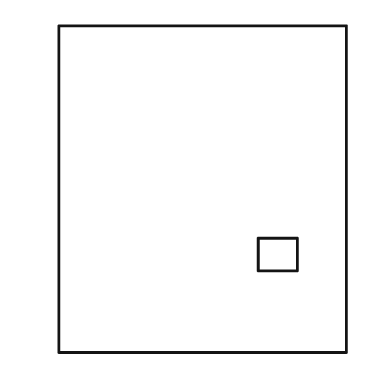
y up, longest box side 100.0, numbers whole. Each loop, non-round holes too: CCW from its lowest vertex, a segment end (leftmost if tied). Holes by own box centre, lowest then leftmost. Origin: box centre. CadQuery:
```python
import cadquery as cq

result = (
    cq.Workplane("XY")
    .moveTo(-44.0, -50.0)
    .lineTo(44.0, -50.0)
    .lineTo(44.0, 50.0)
    .lineTo(-44.0, 50.0)
    .close()
    .moveTo(17.0, -25.0)
    .lineTo(29.0, -25.0)
    .lineTo(29.0, -15.0)
    .lineTo(17.0, -15.0)
    .close()
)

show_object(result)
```